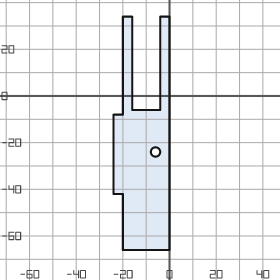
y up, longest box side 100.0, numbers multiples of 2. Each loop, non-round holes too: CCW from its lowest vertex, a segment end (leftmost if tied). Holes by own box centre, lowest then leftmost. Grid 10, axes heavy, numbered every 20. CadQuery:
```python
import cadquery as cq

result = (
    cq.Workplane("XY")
    .moveTo(-20.0, -66.0)
    .lineTo(0.0, -66.0)
    .lineTo(0.0, 34.0)
    .lineTo(-4.0, 34.0)
    .lineTo(-4.0, -6.0)
    .lineTo(-16.0, -6.0)
    .lineTo(-16.0, 34.0)
    .lineTo(-20.0, 34.0)
    .lineTo(-20.0, -8.0)
    .lineTo(-24.0, -8.0)
    .lineTo(-24.0, -42.0)
    .lineTo(-20.0, -42.0)
    .close()
    .moveTo(-6.0, -24.0)
    .circle(2.0)
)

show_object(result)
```